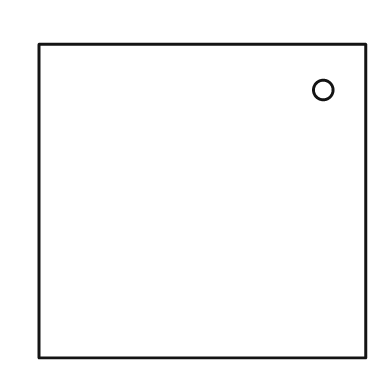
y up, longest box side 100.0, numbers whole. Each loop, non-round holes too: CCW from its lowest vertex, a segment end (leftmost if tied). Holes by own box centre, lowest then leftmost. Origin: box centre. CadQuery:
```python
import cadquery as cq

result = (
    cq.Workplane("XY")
    .moveTo(-50.0, -48.0)
    .lineTo(50.0, -48.0)
    .lineTo(50.0, 48.0)
    .lineTo(-50.0, 48.0)
    .close()
    .moveTo(37.0, 34.0)
    .circle(3.0)
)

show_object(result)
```